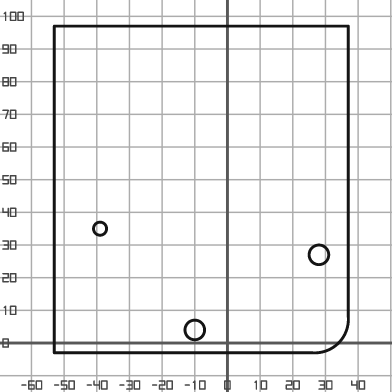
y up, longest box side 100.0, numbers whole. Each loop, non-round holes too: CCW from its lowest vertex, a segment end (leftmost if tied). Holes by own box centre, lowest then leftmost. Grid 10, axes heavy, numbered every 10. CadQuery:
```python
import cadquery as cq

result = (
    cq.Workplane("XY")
    .moveTo(-53.0, -3.0)
    .lineTo(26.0, -3.0)
    .threePointArc((34.0, 0.0), (37.0, 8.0))
    .lineTo(37.0, 97.0)
    .lineTo(-53.0, 97.0)
    .close()
    .moveTo(-10.0, 4.0)
    .circle(3.0)
    .moveTo(28.0, 27.0)
    .circle(3.0)
    .moveTo(-39.0, 35.0)
    .circle(2.0)
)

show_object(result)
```